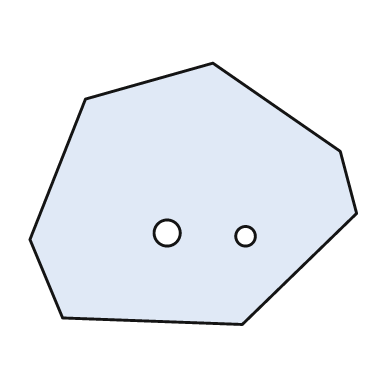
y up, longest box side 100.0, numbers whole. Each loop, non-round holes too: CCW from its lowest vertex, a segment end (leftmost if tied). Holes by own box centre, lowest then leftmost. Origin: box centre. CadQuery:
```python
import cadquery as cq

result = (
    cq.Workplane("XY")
    .moveTo(15.0, -40.0)
    .lineTo(50.0, -6.0)
    .lineTo(45.0, 13.0)
    .lineTo(6.0, 40.0)
    .lineTo(-33.0, 29.0)
    .lineTo(-50.0, -14.0)
    .lineTo(-40.0, -38.0)
    .close()
    .moveTo(16.0, -13.0)
    .circle(3.0)
    .moveTo(-8.0, -12.0)
    .circle(4.0)
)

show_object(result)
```